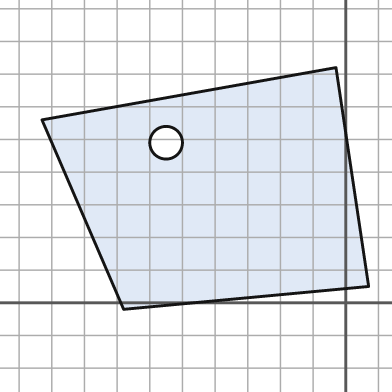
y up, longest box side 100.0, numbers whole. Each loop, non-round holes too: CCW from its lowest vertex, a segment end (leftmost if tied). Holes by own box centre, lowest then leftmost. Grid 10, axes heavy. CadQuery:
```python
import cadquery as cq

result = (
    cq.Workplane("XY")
    .moveTo(-68.0, -2.0)
    .lineTo(7.0, 5.0)
    .lineTo(-3.0, 72.0)
    .lineTo(-93.0, 56.0)
    .close()
    .moveTo(-55.0, 49.0)
    .circle(5.0)
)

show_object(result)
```